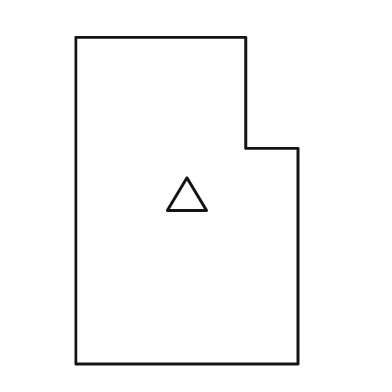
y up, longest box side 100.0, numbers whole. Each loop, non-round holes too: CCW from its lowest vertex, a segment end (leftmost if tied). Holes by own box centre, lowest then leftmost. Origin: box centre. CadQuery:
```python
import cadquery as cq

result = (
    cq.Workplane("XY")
    .moveTo(-34.0, -50.0)
    .lineTo(34.0, -50.0)
    .lineTo(34.0, 16.0)
    .lineTo(18.0, 16.0)
    .lineTo(18.0, 50.0)
    .lineTo(-34.0, 50.0)
    .close()
    .moveTo(-6.0, -3.0)
    .lineTo(6.0, -3.0)
    .lineTo(0.0, 7.0)
    .close()
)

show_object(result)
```